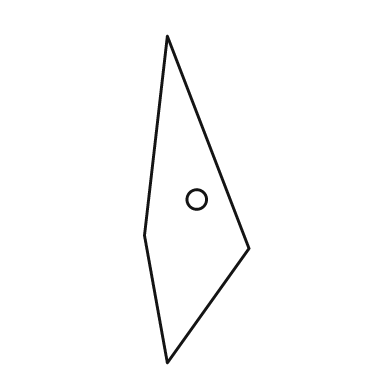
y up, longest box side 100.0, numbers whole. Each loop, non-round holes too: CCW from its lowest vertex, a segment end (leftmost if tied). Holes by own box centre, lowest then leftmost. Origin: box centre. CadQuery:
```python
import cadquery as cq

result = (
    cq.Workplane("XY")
    .moveTo(-9.0, -50.0)
    .lineTo(16.0, -15.0)
    .lineTo(-9.0, 50.0)
    .lineTo(-16.0, -11.0)
    .close()
    .moveTo(0.0, 0.0)
    .circle(3.0)
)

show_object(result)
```